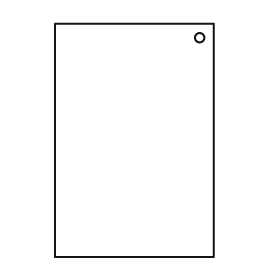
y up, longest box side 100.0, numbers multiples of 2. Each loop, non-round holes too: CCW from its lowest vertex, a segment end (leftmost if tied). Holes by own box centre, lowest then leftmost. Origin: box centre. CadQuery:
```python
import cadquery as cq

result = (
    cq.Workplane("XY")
    .moveTo(-34.0, -50.0)
    .lineTo(34.0, -50.0)
    .lineTo(34.0, 50.0)
    .lineTo(-34.0, 50.0)
    .close()
    .moveTo(28.0, 44.0)
    .circle(2.0)
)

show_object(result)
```